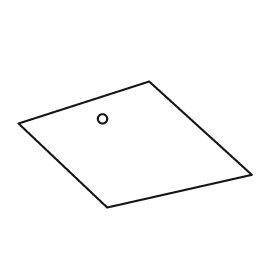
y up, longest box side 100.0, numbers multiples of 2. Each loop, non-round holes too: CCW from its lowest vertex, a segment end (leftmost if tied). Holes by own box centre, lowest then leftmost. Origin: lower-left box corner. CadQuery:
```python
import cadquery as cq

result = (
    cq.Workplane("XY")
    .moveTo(38.0, 0.0)
    .lineTo(100.0, 14.0)
    .lineTo(56.0, 54.0)
    .lineTo(0.0, 36.0)
    .close()
    .moveTo(36.0, 38.0)
    .circle(2.0)
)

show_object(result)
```